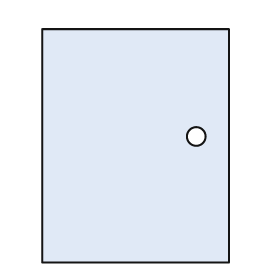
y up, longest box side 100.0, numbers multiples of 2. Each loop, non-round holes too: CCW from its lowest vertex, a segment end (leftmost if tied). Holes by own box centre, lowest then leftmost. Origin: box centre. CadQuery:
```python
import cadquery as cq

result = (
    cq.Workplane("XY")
    .moveTo(-40.0, -50.0)
    .lineTo(40.0, -50.0)
    .lineTo(40.0, 50.0)
    .lineTo(-40.0, 50.0)
    .close()
    .moveTo(26.0, 4.0)
    .circle(4.0)
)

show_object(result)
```